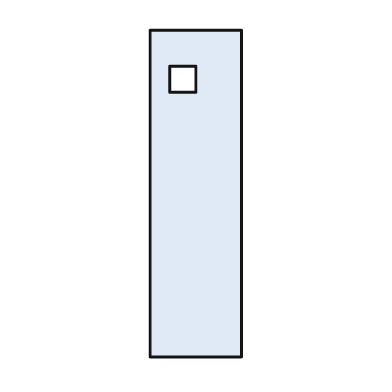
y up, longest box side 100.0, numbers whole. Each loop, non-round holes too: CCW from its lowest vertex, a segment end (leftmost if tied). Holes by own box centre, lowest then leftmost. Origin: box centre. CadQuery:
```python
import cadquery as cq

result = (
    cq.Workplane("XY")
    .moveTo(-14.0, -50.0)
    .lineTo(14.0, -50.0)
    .lineTo(14.0, 50.0)
    .lineTo(-14.0, 50.0)
    .close()
    .moveTo(-8.0, 31.0)
    .lineTo(0.0, 31.0)
    .lineTo(0.0, 39.0)
    .lineTo(-8.0, 39.0)
    .close()
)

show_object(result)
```